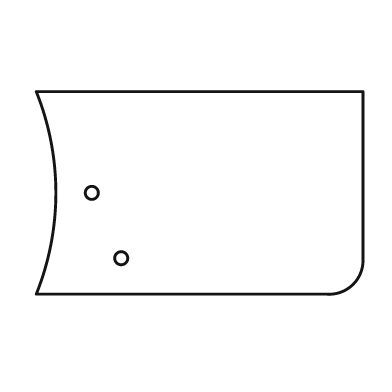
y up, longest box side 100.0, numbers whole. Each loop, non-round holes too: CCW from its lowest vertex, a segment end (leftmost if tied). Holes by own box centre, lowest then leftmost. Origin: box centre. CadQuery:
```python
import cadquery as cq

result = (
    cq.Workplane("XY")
    .moveTo(-50.0, -31.0)
    .lineTo(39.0, -31.0)
    .threePointArc((47.0, -28.0), (50.0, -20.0))
    .lineTo(50.0, 31.0)
    .lineTo(-50.0, 31.0)
    .threePointArc((-44.0, 0.0), (-50.0, -31.0))
    .close()
    .moveTo(-24.0, -20.0)
    .circle(2.0)
    .moveTo(-33.0, 0.0)
    .circle(2.0)
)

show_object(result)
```